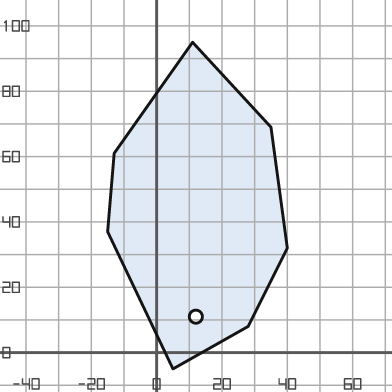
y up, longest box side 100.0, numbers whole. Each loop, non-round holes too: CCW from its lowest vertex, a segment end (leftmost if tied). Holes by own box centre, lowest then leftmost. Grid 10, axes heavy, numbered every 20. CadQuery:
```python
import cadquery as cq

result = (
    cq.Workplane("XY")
    .moveTo(5.0, -5.0)
    .lineTo(28.0, 8.0)
    .lineTo(40.0, 32.0)
    .lineTo(35.0, 69.0)
    .lineTo(11.0, 95.0)
    .lineTo(-13.0, 61.0)
    .lineTo(-15.0, 37.0)
    .close()
    .moveTo(12.0, 11.0)
    .circle(2.0)
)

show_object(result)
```